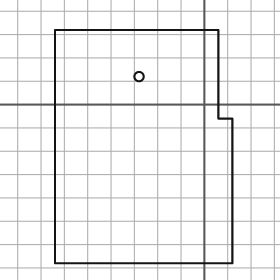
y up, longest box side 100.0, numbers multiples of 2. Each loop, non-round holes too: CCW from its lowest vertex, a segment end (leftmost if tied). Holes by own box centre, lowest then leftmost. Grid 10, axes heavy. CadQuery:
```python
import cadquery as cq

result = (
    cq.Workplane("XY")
    .moveTo(-64.0, -68.0)
    .lineTo(12.0, -68.0)
    .lineTo(12.0, -6.0)
    .lineTo(6.0, -6.0)
    .lineTo(6.0, 32.0)
    .lineTo(-64.0, 32.0)
    .close()
    .moveTo(-28.0, 12.0)
    .circle(2.0)
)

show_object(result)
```